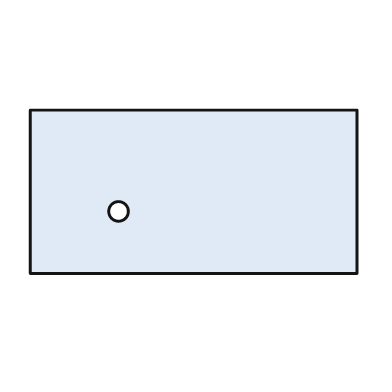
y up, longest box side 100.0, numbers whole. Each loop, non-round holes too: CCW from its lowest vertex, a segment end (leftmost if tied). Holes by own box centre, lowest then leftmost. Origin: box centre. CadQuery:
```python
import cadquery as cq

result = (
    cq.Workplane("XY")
    .moveTo(-50.0, -25.0)
    .lineTo(50.0, -25.0)
    .lineTo(50.0, 25.0)
    .lineTo(-50.0, 25.0)
    .close()
    .moveTo(-23.0, -6.0)
    .circle(3.0)
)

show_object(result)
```